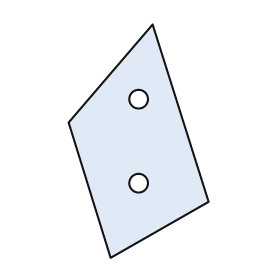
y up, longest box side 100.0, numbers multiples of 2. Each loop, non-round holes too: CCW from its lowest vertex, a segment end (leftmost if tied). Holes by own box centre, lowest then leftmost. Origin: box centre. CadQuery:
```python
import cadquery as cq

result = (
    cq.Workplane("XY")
    .moveTo(-12.0, -50.0)
    .lineTo(30.0, -26.0)
    .lineTo(6.0, 50.0)
    .lineTo(-30.0, 8.0)
    .close()
    .moveTo(0.0, -18.0)
    .circle(4.0)
    .moveTo(0.0, 18.0)
    .circle(4.0)
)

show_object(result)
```